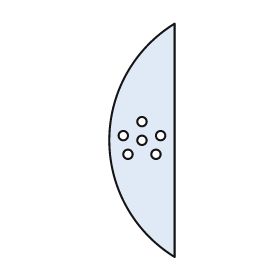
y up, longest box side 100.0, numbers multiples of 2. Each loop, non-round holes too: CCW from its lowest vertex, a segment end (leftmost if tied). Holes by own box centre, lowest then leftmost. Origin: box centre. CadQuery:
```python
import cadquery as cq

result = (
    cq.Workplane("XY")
    .moveTo(14.0, -50.0)
    .lineTo(14.0, 50.0)
    .threePointArc((-14.0, 0.0), (14.0, -50.0))
    .close()
    .moveTo(-6.0, -6.0)
    .circle(2.0)
    .moveTo(6.0, -6.0)
    .circle(2.0)
    .moveTo(0.0, 0.0)
    .circle(2.0)
    .moveTo(-8.0, 2.0)
    .circle(2.0)
    .moveTo(8.0, 2.0)
    .circle(2.0)
    .moveTo(0.0, 8.0)
    .circle(2.0)
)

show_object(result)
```